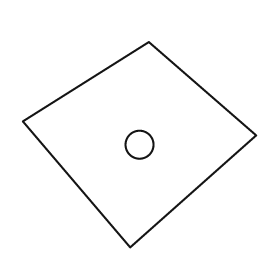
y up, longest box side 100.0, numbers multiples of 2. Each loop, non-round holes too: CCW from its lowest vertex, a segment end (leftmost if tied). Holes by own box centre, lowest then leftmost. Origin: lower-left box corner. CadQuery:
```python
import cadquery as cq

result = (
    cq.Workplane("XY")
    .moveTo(46.0, 0.0)
    .lineTo(100.0, 48.0)
    .lineTo(54.0, 88.0)
    .lineTo(0.0, 54.0)
    .close()
    .moveTo(50.0, 44.0)
    .circle(6.0)
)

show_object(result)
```